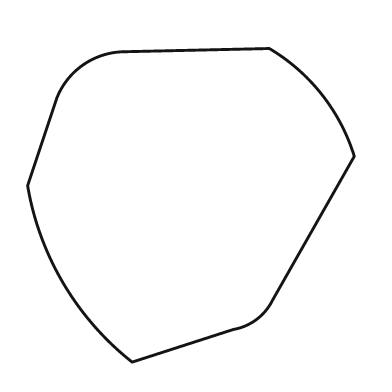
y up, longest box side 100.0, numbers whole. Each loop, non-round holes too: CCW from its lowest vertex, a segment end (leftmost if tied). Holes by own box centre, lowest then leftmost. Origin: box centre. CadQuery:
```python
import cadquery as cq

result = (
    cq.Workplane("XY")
    .moveTo(-18.0, -48.0)
    .lineTo(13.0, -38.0)
    .threePointArc((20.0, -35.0), (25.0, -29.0))
    .lineTo(50.0, 15.0)
    .threePointArc((40.0, 34.0), (24.0, 48.0))
    .lineTo(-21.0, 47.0)
    .threePointArc((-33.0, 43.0), (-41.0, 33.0))
    .lineTo(-50.0, 6.0)
    .threePointArc((-39.0, -24.0), (-18.0, -48.0))
    .close()
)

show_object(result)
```